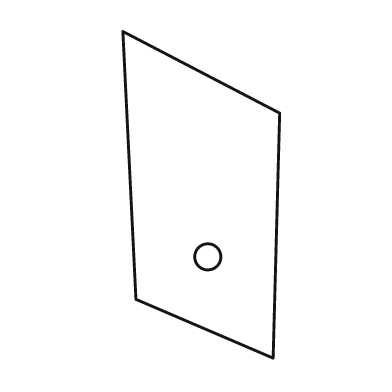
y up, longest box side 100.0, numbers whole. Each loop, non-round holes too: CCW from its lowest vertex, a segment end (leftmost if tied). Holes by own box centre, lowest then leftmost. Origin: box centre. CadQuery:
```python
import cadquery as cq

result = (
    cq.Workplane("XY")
    .moveTo(22.0, -50.0)
    .lineTo(24.0, 25.0)
    .lineTo(-24.0, 50.0)
    .lineTo(-20.0, -32.0)
    .close()
    .moveTo(2.0, -19.0)
    .circle(4.0)
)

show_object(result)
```